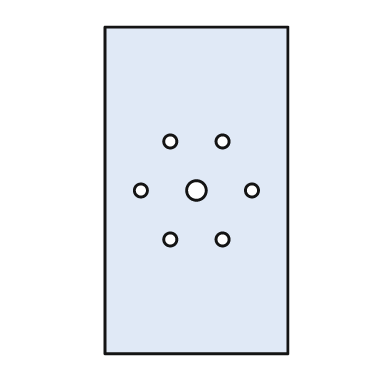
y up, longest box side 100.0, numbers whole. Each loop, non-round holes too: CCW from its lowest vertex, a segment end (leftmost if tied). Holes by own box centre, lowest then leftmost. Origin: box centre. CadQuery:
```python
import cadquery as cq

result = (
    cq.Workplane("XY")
    .moveTo(-28.0, -50.0)
    .lineTo(28.0, -50.0)
    .lineTo(28.0, 50.0)
    .lineTo(-28.0, 50.0)
    .close()
    .moveTo(-8.0, -15.0)
    .circle(2.0)
    .moveTo(8.0, -15.0)
    .circle(2.0)
    .moveTo(-17.0, 0.0)
    .circle(2.0)
    .moveTo(0.0, 0.0)
    .circle(3.0)
    .moveTo(17.0, 0.0)
    .circle(2.0)
    .moveTo(-8.0, 15.0)
    .circle(2.0)
    .moveTo(8.0, 15.0)
    .circle(2.0)
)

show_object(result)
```